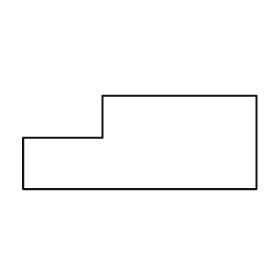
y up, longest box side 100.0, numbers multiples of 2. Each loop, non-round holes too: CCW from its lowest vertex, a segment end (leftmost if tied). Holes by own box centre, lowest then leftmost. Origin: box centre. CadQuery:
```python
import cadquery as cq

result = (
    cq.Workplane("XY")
    .moveTo(-50.0, -20.0)
    .lineTo(50.0, -20.0)
    .lineTo(50.0, 20.0)
    .lineTo(-16.0, 20.0)
    .lineTo(-16.0, 2.0)
    .lineTo(-50.0, 2.0)
    .close()
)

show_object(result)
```